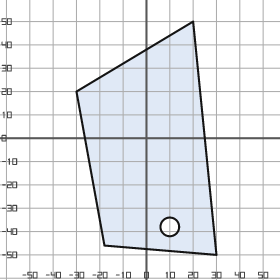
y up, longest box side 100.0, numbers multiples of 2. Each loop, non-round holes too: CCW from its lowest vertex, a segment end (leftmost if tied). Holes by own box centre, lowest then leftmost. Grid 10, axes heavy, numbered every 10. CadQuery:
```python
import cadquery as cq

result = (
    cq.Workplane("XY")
    .moveTo(30.0, -50.0)
    .lineTo(20.0, 50.0)
    .lineTo(-30.0, 20.0)
    .lineTo(-18.0, -46.0)
    .close()
    .moveTo(10.0, -38.0)
    .circle(4.0)
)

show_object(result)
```